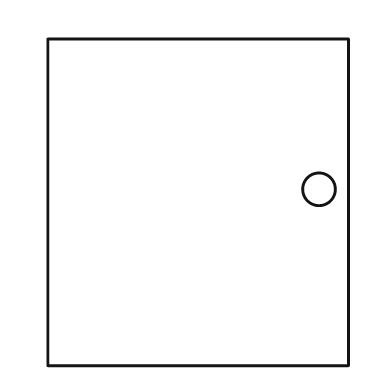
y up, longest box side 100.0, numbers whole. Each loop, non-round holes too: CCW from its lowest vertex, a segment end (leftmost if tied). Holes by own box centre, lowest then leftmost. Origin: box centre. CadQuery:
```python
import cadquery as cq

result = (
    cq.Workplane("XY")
    .moveTo(-46.0, -50.0)
    .lineTo(46.0, -50.0)
    .lineTo(46.0, 50.0)
    .lineTo(-46.0, 50.0)
    .close()
    .moveTo(37.0, 4.0)
    .circle(5.0)
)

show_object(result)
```